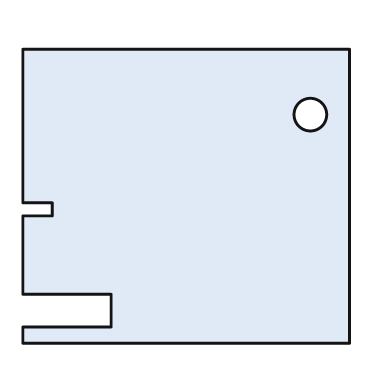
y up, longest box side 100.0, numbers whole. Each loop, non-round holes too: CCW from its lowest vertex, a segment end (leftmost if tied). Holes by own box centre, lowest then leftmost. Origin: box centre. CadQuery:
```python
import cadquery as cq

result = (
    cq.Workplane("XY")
    .moveTo(-50.0, -45.0)
    .lineTo(50.0, -45.0)
    .lineTo(50.0, 45.0)
    .lineTo(-50.0, 45.0)
    .lineTo(-50.0, -2.0)
    .lineTo(-41.0, -2.0)
    .lineTo(-41.0, -6.0)
    .lineTo(-50.0, -6.0)
    .lineTo(-50.0, -30.0)
    .lineTo(-23.0, -30.0)
    .lineTo(-23.0, -40.0)
    .lineTo(-50.0, -40.0)
    .close()
    .moveTo(38.0, 25.0)
    .circle(5.0)
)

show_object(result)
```